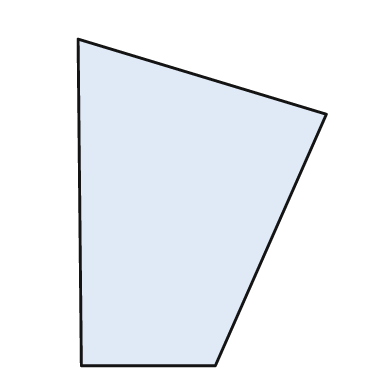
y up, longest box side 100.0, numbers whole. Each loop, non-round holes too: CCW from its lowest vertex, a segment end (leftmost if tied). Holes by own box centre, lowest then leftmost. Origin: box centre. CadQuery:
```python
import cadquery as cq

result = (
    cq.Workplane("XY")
    .moveTo(-37.0, -50.0)
    .lineTo(4.0, -50.0)
    .lineTo(38.0, 27.0)
    .lineTo(-38.0, 50.0)
    .close()
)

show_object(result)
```